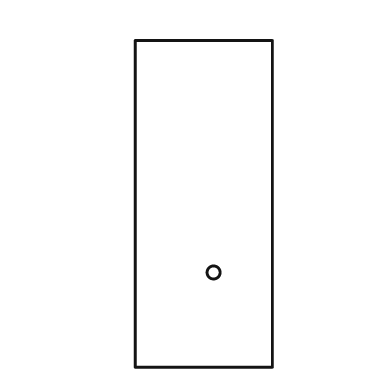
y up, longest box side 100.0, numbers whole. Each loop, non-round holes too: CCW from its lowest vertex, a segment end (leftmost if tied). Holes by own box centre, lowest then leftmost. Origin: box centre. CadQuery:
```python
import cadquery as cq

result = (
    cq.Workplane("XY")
    .moveTo(-21.0, -50.0)
    .lineTo(21.0, -50.0)
    .lineTo(21.0, 50.0)
    .lineTo(-21.0, 50.0)
    .close()
    .moveTo(3.0, -21.0)
    .circle(2.0)
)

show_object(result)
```